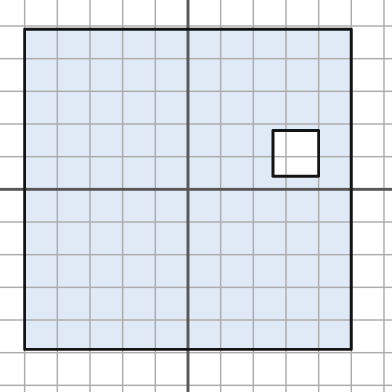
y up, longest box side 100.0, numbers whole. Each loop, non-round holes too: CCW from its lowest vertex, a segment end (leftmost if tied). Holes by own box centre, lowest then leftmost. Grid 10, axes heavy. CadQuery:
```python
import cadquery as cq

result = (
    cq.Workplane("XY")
    .moveTo(-50.0, -49.0)
    .lineTo(50.0, -49.0)
    .lineTo(50.0, 49.0)
    .lineTo(-50.0, 49.0)
    .close()
    .moveTo(26.0, 4.0)
    .lineTo(40.0, 4.0)
    .lineTo(40.0, 18.0)
    .lineTo(26.0, 18.0)
    .close()
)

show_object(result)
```